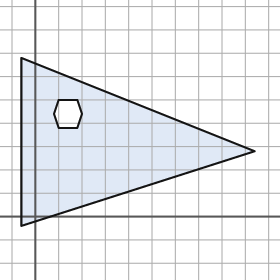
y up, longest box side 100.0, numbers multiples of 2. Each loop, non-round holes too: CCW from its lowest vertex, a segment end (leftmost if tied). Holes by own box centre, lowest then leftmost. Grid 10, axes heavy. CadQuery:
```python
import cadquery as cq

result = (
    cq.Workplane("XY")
    .moveTo(-6.0, -4.0)
    .lineTo(94.0, 28.0)
    .lineTo(-6.0, 68.0)
    .close()
    .moveTo(10.0, 38.0)
    .lineTo(18.0, 38.0)
    .lineTo(20.0, 44.0)
    .lineTo(18.0, 50.0)
    .lineTo(10.0, 50.0)
    .lineTo(8.0, 44.0)
    .close()
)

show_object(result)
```